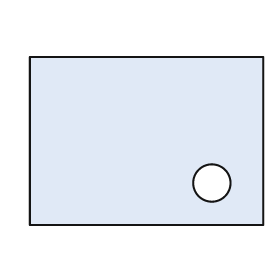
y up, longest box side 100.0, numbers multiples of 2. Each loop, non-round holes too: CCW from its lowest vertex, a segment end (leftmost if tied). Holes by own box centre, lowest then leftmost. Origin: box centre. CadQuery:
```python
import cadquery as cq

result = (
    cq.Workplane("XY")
    .moveTo(-50.0, -36.0)
    .lineTo(50.0, -36.0)
    .lineTo(50.0, 36.0)
    .lineTo(-50.0, 36.0)
    .close()
    .moveTo(28.0, -18.0)
    .circle(8.0)
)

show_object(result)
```